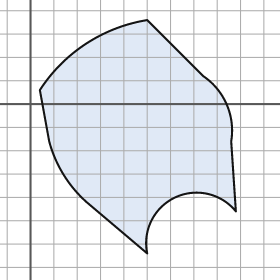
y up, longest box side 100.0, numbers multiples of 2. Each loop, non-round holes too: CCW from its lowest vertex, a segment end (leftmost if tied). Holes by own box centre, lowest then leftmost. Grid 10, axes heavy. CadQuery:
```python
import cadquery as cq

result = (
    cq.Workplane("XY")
    .moveTo(50.0, -64.0)
    .threePointArc((62.0, -40.0), (88.0, -46.0))
    .lineTo(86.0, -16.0)
    .threePointArc((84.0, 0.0), (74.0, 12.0))
    .lineTo(50.0, 36.0)
    .threePointArc((24.0, 26.0), (4.0, 6.0))
    .lineTo(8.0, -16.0)
    .threePointArc((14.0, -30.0), (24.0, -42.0))
    .close()
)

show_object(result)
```